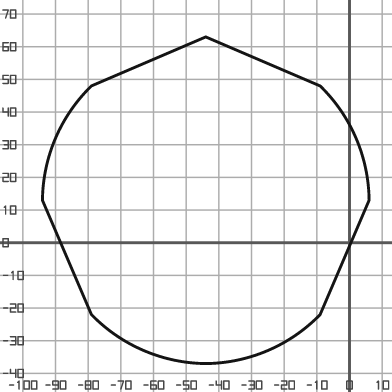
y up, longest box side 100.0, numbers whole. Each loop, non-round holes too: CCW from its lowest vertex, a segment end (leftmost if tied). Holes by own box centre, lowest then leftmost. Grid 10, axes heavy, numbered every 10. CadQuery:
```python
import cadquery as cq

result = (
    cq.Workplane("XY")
    .moveTo(-44.0, -37.0)
    .threePointArc((-25.0, -33.0), (-9.0, -22.0))
    .lineTo(6.0, 13.0)
    .threePointArc((2.0, 32.0), (-9.0, 48.0))
    .lineTo(-44.0, 63.0)
    .lineTo(-79.0, 48.0)
    .threePointArc((-90.0, 32.0), (-94.0, 13.0))
    .lineTo(-79.0, -22.0)
    .threePointArc((-63.0, -33.0), (-44.0, -37.0))
    .close()
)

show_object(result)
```